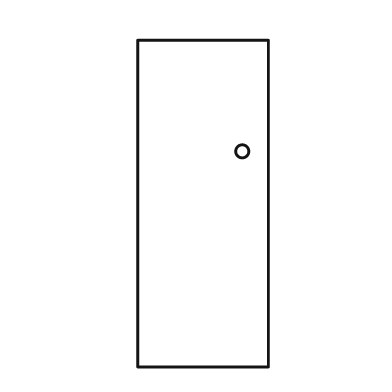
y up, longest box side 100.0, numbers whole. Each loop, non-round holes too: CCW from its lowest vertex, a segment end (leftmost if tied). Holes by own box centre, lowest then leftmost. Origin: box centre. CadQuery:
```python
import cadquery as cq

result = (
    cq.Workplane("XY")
    .moveTo(-20.0, -50.0)
    .lineTo(20.0, -50.0)
    .lineTo(20.0, 50.0)
    .lineTo(-20.0, 50.0)
    .close()
    .moveTo(12.0, 16.0)
    .circle(2.0)
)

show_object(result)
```